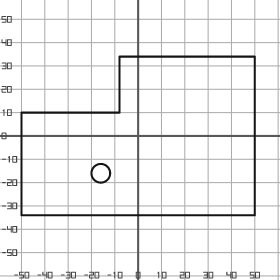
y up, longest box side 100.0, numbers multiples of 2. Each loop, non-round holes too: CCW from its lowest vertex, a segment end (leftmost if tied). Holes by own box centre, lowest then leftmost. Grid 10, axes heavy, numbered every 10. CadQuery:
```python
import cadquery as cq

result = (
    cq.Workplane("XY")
    .moveTo(-50.0, -34.0)
    .lineTo(50.0, -34.0)
    .lineTo(50.0, 34.0)
    .lineTo(-8.0, 34.0)
    .lineTo(-8.0, 10.0)
    .lineTo(-50.0, 10.0)
    .close()
    .moveTo(-16.0, -16.0)
    .circle(4.0)
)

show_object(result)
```